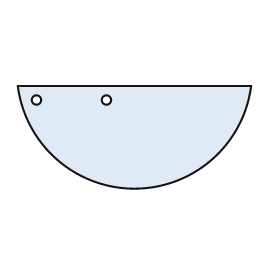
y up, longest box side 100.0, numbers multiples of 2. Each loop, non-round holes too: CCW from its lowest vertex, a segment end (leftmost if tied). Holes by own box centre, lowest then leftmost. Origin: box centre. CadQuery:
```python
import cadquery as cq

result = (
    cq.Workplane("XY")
    .moveTo(-50.0, 22.0)
    .threePointArc((0.0, -22.0), (50.0, 22.0))
    .close()
    .moveTo(-42.0, 16.0)
    .circle(2.0)
    .moveTo(-12.0, 16.0)
    .circle(2.0)
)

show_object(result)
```